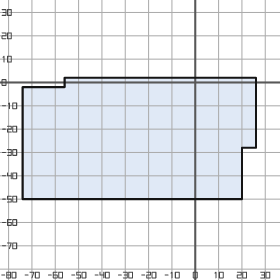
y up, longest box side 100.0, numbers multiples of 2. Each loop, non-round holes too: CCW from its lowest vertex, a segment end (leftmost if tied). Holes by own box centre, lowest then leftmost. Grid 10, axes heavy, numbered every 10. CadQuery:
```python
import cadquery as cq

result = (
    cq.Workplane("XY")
    .moveTo(-74.0, -50.0)
    .lineTo(20.0, -50.0)
    .lineTo(20.0, -28.0)
    .lineTo(26.0, -28.0)
    .lineTo(26.0, 2.0)
    .lineTo(-56.0, 2.0)
    .lineTo(-56.0, -2.0)
    .lineTo(-74.0, -2.0)
    .close()
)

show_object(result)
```